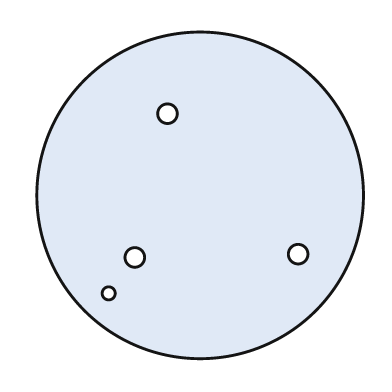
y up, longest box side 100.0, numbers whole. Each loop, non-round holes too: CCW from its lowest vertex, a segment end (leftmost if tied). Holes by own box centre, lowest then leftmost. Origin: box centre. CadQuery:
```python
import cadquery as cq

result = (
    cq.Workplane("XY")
    .moveTo(0.0, 0.0)
    .circle(50.0)
    .moveTo(-28.0, -30.0)
    .circle(2.0)
    .moveTo(-20.0, -19.0)
    .circle(3.0)
    .moveTo(30.0, -18.0)
    .circle(3.0)
    .moveTo(-10.0, 25.0)
    .circle(3.0)
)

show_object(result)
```